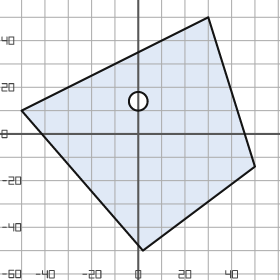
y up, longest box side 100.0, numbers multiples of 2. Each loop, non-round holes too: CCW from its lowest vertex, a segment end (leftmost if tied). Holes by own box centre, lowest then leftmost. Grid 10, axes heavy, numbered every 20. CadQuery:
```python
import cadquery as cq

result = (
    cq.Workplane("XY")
    .moveTo(2.0, -50.0)
    .lineTo(50.0, -14.0)
    .lineTo(30.0, 50.0)
    .lineTo(-50.0, 10.0)
    .close()
    .moveTo(0.0, 14.0)
    .circle(4.0)
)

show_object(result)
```